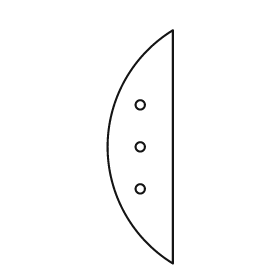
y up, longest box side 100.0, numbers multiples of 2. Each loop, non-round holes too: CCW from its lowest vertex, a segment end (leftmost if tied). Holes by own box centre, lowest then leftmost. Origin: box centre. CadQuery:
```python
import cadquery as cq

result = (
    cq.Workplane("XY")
    .moveTo(14.0, -50.0)
    .lineTo(14.0, 50.0)
    .threePointArc((-14.0, 0.0), (14.0, -50.0))
    .close()
    .moveTo(0.0, -18.0)
    .circle(2.0)
    .moveTo(0.0, 0.0)
    .circle(2.0)
    .moveTo(0.0, 18.0)
    .circle(2.0)
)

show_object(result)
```